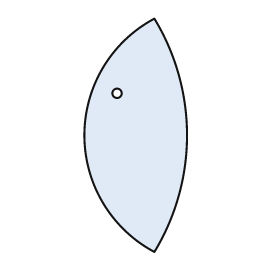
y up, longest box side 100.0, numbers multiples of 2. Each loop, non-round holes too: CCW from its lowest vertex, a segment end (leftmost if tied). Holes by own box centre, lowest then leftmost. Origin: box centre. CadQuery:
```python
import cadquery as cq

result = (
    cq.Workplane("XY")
    .moveTo(8.0, -50.0)
    .threePointArc((22.0, 0.0), (8.0, 50.0))
    .threePointArc((-22.0, 0.0), (8.0, -50.0))
    .close()
    .moveTo(-8.0, 18.0)
    .circle(2.0)
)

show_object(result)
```